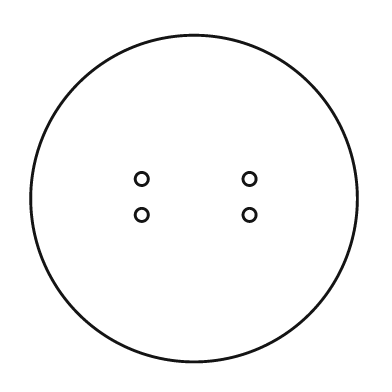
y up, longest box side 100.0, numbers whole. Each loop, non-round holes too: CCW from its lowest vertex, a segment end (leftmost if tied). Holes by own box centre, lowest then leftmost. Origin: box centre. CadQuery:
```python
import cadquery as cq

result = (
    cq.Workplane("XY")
    .moveTo(0.0, 0.0)
    .circle(50.0)
    .moveTo(-16.0, -5.0)
    .circle(2.0)
    .moveTo(17.0, -5.0)
    .circle(2.0)
    .moveTo(-16.0, 6.0)
    .circle(2.0)
    .moveTo(17.0, 6.0)
    .circle(2.0)
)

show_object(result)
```